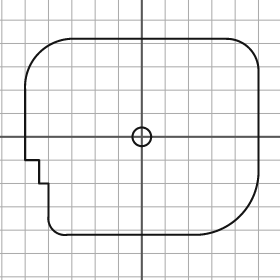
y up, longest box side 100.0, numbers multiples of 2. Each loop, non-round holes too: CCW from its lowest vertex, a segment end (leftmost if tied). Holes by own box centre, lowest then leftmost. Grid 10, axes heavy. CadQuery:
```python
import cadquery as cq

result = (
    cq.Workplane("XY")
    .moveTo(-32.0, -42.0)
    .lineTo(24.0, -42.0)
    .threePointArc((42.0, -34.0), (50.0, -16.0))
    .lineTo(50.0, 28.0)
    .threePointArc((46.0, 38.0), (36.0, 42.0))
    .lineTo(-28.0, 42.0)
    .threePointArc((-44.0, 36.0), (-50.0, 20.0))
    .lineTo(-50.0, -10.0)
    .lineTo(-44.0, -10.0)
    .lineTo(-44.0, -20.0)
    .lineTo(-40.0, -20.0)
    .lineTo(-40.0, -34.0)
    .threePointArc((-38.0, -40.0), (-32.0, -42.0))
    .close()
    .moveTo(0.0, 0.0)
    .circle(4.0)
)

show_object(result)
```